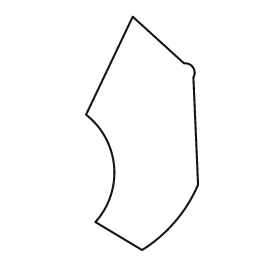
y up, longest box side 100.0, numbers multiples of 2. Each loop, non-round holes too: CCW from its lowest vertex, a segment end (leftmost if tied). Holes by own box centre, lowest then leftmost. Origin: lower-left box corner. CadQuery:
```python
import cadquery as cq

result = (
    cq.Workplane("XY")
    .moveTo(24.0, 0.0)
    .threePointArc((38.0, 12.0), (48.0, 28.0))
    .lineTo(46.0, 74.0)
    .threePointArc((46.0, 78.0), (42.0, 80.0))
    .lineTo(20.0, 100.0)
    .lineTo(0.0, 58.0)
    .threePointArc((12.0, 36.0), (4.0, 12.0))
    .close()
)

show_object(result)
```